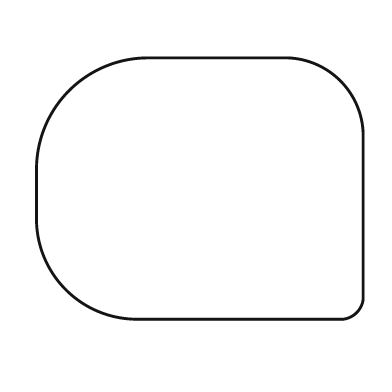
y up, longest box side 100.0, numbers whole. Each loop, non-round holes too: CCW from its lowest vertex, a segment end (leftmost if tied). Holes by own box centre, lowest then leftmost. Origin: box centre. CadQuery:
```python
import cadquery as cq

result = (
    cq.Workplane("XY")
    .moveTo(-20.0, -40.0)
    .lineTo(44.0, -40.0)
    .threePointArc((48.0, -38.0), (50.0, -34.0))
    .lineTo(50.0, 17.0)
    .threePointArc((43.0, 33.0), (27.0, 40.0))
    .lineTo(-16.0, 40.0)
    .threePointArc((-40.0, 30.0), (-50.0, 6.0))
    .lineTo(-50.0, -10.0)
    .threePointArc((-41.0, -31.0), (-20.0, -40.0))
    .close()
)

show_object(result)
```